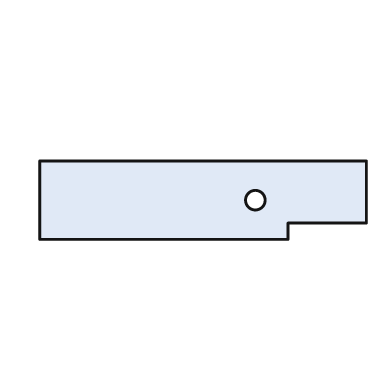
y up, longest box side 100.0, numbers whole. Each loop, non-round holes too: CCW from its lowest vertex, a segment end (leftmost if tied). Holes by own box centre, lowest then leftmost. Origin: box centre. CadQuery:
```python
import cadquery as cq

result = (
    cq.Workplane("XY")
    .moveTo(-50.0, -12.0)
    .lineTo(26.0, -12.0)
    .lineTo(26.0, -7.0)
    .lineTo(50.0, -7.0)
    .lineTo(50.0, 12.0)
    .lineTo(-50.0, 12.0)
    .close()
    .moveTo(16.0, 0.0)
    .circle(3.0)
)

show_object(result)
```